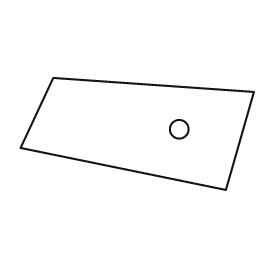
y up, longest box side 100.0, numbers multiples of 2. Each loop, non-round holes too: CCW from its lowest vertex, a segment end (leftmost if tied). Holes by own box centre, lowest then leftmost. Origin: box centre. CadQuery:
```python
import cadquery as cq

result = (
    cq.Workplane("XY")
    .moveTo(38.0, -24.0)
    .lineTo(50.0, 18.0)
    .lineTo(-36.0, 24.0)
    .lineTo(-50.0, -6.0)
    .close()
    .moveTo(18.0, 2.0)
    .circle(4.0)
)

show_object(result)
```